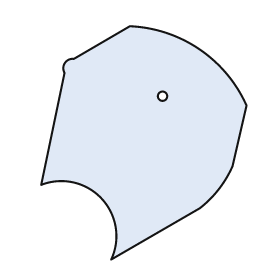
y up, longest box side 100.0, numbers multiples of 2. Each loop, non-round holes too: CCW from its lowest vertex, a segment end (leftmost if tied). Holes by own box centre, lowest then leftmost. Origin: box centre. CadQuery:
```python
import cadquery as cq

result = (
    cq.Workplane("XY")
    .moveTo(-14.0, -50.0)
    .lineTo(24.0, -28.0)
    .threePointArc((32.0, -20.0), (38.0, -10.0))
    .lineTo(44.0, 16.0)
    .threePointArc((24.0, 40.0), (-6.0, 50.0))
    .lineTo(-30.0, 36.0)
    .threePointArc((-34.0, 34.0), (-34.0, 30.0))
    .lineTo(-44.0, -18.0)
    .threePointArc((-18.0, -24.0), (-14.0, -50.0))
    .close()
    .moveTo(8.0, 20.0)
    .circle(2.0)
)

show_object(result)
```